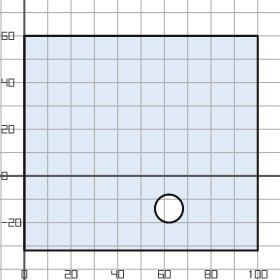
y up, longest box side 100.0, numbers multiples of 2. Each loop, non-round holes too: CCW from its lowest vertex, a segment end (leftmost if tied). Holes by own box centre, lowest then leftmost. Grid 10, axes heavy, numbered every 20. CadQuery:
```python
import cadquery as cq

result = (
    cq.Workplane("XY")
    .moveTo(0.0, -32.0)
    .lineTo(100.0, -32.0)
    .lineTo(100.0, 60.0)
    .lineTo(0.0, 60.0)
    .close()
    .moveTo(62.0, -14.0)
    .circle(6.0)
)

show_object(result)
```